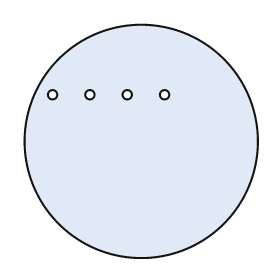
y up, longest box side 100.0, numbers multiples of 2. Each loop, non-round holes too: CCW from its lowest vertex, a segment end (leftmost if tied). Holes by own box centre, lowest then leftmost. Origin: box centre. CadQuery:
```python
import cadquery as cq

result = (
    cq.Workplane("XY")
    .moveTo(0.0, 0.0)
    .circle(50.0)
    .moveTo(-38.0, 20.0)
    .circle(2.0)
    .moveTo(-22.0, 20.0)
    .circle(2.0)
    .moveTo(-6.0, 20.0)
    .circle(2.0)
    .moveTo(10.0, 20.0)
    .circle(2.0)
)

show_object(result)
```